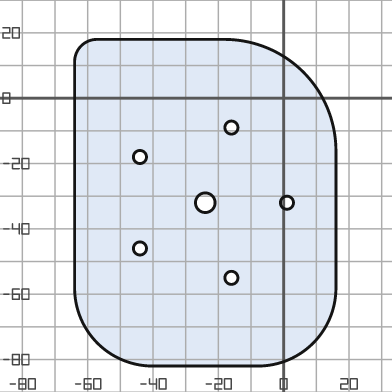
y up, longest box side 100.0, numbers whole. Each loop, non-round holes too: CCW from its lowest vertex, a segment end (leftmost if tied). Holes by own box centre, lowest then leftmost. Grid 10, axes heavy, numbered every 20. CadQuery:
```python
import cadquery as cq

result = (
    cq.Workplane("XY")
    .moveTo(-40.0, -82.0)
    .lineTo(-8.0, -82.0)
    .threePointArc((9.0, -75.0), (16.0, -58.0))
    .lineTo(16.0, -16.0)
    .threePointArc((6.0, 8.0), (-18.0, 18.0))
    .lineTo(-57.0, 18.0)
    .threePointArc((-62.0, 16.0), (-64.0, 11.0))
    .lineTo(-64.0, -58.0)
    .threePointArc((-57.0, -75.0), (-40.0, -82.0))
    .close()
    .moveTo(-16.0, -55.0)
    .circle(2.0)
    .moveTo(-44.0, -46.0)
    .circle(2.0)
    .moveTo(-24.0, -32.0)
    .circle(3.0)
    .moveTo(1.0, -32.0)
    .circle(2.0)
    .moveTo(-44.0, -18.0)
    .circle(2.0)
    .moveTo(-16.0, -9.0)
    .circle(2.0)
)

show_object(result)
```